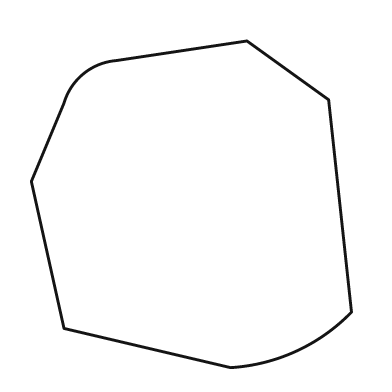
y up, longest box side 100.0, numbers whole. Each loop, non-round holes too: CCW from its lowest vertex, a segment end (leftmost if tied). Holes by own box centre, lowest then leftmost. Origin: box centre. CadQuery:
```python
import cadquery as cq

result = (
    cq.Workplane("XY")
    .moveTo(12.0, -50.0)
    .threePointArc((32.0, -45.0), (49.0, -33.0))
    .lineTo(42.0, 32.0)
    .lineTo(17.0, 50.0)
    .lineTo(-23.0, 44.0)
    .threePointArc((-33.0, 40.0), (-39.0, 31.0))
    .lineTo(-49.0, 7.0)
    .lineTo(-39.0, -38.0)
    .close()
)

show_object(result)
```